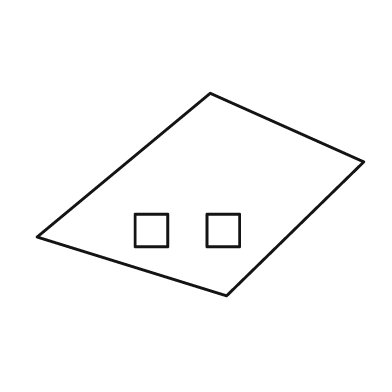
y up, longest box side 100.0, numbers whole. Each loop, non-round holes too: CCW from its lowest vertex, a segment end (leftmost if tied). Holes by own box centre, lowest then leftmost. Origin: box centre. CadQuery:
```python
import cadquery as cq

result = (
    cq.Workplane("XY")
    .moveTo(8.0, -31.0)
    .lineTo(50.0, 10.0)
    .lineTo(3.0, 31.0)
    .lineTo(-50.0, -13.0)
    .close()
    .moveTo(-20.0, -16.0)
    .lineTo(-10.0, -16.0)
    .lineTo(-10.0, -6.0)
    .lineTo(-20.0, -6.0)
    .close()
    .moveTo(2.0, -16.0)
    .lineTo(12.0, -16.0)
    .lineTo(12.0, -6.0)
    .lineTo(2.0, -6.0)
    .close()
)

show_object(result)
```